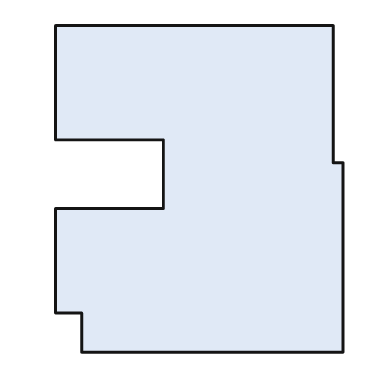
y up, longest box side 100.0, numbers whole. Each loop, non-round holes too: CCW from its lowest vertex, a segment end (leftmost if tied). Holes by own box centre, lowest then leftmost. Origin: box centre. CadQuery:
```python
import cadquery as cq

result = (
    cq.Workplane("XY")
    .moveTo(-36.0, -50.0)
    .lineTo(44.0, -50.0)
    .lineTo(44.0, 8.0)
    .lineTo(41.0, 8.0)
    .lineTo(41.0, 50.0)
    .lineTo(-44.0, 50.0)
    .lineTo(-44.0, 15.0)
    .lineTo(-11.0, 15.0)
    .lineTo(-11.0, -6.0)
    .lineTo(-44.0, -6.0)
    .lineTo(-44.0, -38.0)
    .lineTo(-36.0, -38.0)
    .close()
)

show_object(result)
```